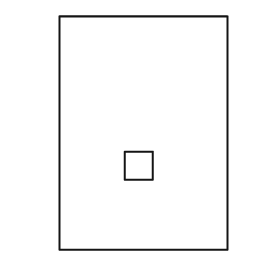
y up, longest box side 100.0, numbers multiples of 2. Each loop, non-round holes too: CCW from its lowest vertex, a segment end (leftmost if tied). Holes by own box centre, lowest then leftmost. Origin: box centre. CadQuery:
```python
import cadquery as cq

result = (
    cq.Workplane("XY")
    .moveTo(-36.0, -50.0)
    .lineTo(36.0, -50.0)
    .lineTo(36.0, 50.0)
    .lineTo(-36.0, 50.0)
    .close()
    .moveTo(-8.0, -20.0)
    .lineTo(4.0, -20.0)
    .lineTo(4.0, -8.0)
    .lineTo(-8.0, -8.0)
    .close()
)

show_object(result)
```